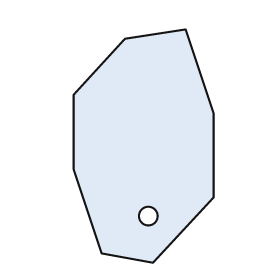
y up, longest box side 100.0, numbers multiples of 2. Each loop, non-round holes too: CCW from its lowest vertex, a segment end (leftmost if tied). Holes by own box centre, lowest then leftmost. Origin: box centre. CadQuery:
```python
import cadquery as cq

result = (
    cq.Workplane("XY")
    .moveTo(4.0, -50.0)
    .lineTo(30.0, -22.0)
    .lineTo(30.0, 14.0)
    .lineTo(18.0, 50.0)
    .lineTo(-8.0, 46.0)
    .lineTo(-30.0, 22.0)
    .lineTo(-30.0, -10.0)
    .lineTo(-18.0, -46.0)
    .close()
    .moveTo(2.0, -30.0)
    .circle(4.0)
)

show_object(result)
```